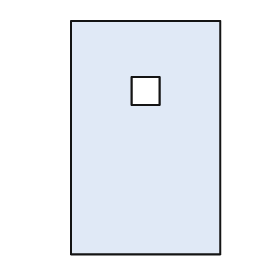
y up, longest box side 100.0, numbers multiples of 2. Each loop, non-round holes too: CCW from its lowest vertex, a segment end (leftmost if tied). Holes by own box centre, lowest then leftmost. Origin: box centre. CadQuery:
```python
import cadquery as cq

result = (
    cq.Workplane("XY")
    .moveTo(-32.0, -50.0)
    .lineTo(32.0, -50.0)
    .lineTo(32.0, 50.0)
    .lineTo(-32.0, 50.0)
    .close()
    .moveTo(-6.0, 14.0)
    .lineTo(6.0, 14.0)
    .lineTo(6.0, 26.0)
    .lineTo(-6.0, 26.0)
    .close()
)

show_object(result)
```